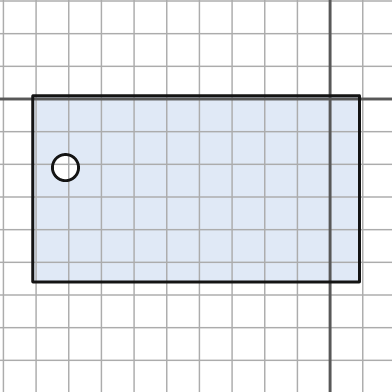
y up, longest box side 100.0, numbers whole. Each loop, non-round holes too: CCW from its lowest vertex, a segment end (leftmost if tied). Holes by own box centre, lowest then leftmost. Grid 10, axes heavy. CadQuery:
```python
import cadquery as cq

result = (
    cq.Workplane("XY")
    .moveTo(-91.0, -56.0)
    .lineTo(9.0, -56.0)
    .lineTo(9.0, 1.0)
    .lineTo(-91.0, 1.0)
    .close()
    .moveTo(-81.0, -21.0)
    .circle(4.0)
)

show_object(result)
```